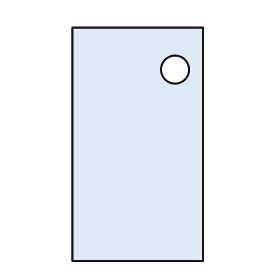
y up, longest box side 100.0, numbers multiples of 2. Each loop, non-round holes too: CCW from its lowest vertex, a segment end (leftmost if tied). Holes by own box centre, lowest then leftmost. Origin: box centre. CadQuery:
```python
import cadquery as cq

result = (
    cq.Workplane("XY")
    .moveTo(-28.0, -50.0)
    .lineTo(28.0, -50.0)
    .lineTo(28.0, 50.0)
    .lineTo(-28.0, 50.0)
    .close()
    .moveTo(16.0, 32.0)
    .circle(6.0)
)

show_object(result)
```